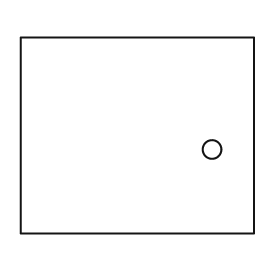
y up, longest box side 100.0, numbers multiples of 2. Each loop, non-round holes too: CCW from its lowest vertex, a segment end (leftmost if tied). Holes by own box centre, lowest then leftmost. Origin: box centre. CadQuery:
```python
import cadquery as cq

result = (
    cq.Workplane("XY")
    .moveTo(-50.0, -42.0)
    .lineTo(50.0, -42.0)
    .lineTo(50.0, 42.0)
    .lineTo(-50.0, 42.0)
    .close()
    .moveTo(32.0, -6.0)
    .circle(4.0)
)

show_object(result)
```